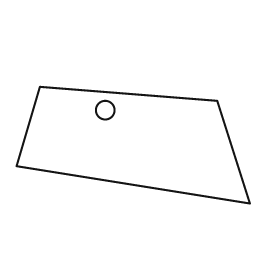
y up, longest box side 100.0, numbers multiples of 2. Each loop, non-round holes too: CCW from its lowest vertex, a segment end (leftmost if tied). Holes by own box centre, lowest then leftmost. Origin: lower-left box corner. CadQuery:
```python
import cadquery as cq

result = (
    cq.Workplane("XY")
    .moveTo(100.0, 0.0)
    .lineTo(86.0, 44.0)
    .lineTo(10.0, 50.0)
    .lineTo(0.0, 16.0)
    .close()
    .moveTo(38.0, 40.0)
    .circle(4.0)
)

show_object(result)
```